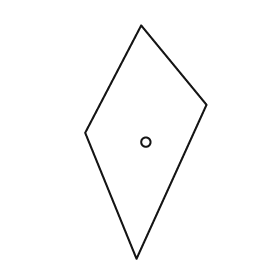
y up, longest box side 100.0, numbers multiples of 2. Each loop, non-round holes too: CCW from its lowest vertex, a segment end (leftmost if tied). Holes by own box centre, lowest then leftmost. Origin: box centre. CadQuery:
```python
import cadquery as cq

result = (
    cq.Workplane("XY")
    .moveTo(-4.0, -50.0)
    .lineTo(26.0, 16.0)
    .lineTo(-2.0, 50.0)
    .lineTo(-26.0, 4.0)
    .close()
    .moveTo(0.0, 0.0)
    .circle(2.0)
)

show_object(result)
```